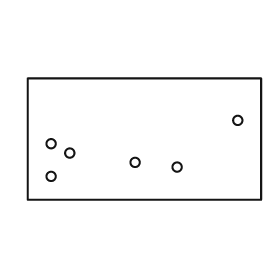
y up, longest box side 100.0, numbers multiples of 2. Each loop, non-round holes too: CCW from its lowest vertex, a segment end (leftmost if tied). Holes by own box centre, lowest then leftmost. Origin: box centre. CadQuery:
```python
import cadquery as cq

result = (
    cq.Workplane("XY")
    .moveTo(-50.0, -26.0)
    .lineTo(50.0, -26.0)
    .lineTo(50.0, 26.0)
    .lineTo(-50.0, 26.0)
    .close()
    .moveTo(-40.0, -16.0)
    .circle(2.0)
    .moveTo(14.0, -12.0)
    .circle(2.0)
    .moveTo(-4.0, -10.0)
    .circle(2.0)
    .moveTo(-32.0, -6.0)
    .circle(2.0)
    .moveTo(-40.0, -2.0)
    .circle(2.0)
    .moveTo(40.0, 8.0)
    .circle(2.0)
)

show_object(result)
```